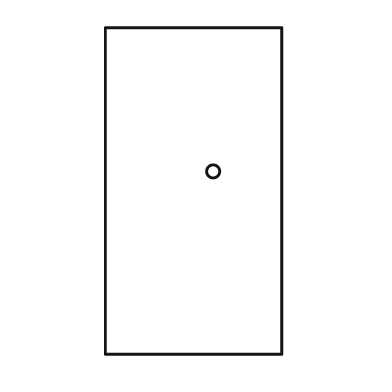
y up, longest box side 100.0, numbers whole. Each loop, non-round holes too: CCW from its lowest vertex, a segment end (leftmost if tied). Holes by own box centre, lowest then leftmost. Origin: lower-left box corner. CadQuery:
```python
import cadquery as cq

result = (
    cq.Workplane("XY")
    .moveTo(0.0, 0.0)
    .lineTo(54.0, 0.0)
    .lineTo(54.0, 100.0)
    .lineTo(0.0, 100.0)
    .close()
    .moveTo(33.0, 56.0)
    .circle(2.0)
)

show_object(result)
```